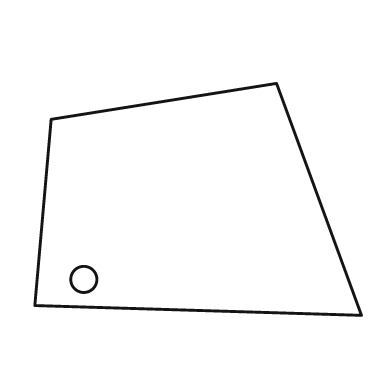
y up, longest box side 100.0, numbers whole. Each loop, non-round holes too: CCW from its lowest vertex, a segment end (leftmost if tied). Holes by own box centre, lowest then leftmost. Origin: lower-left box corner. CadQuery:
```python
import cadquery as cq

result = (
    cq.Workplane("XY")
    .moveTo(100.0, 0.0)
    .lineTo(74.0, 71.0)
    .lineTo(5.0, 60.0)
    .lineTo(0.0, 3.0)
    .close()
    .moveTo(15.0, 11.0)
    .circle(4.0)
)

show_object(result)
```